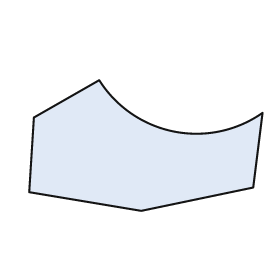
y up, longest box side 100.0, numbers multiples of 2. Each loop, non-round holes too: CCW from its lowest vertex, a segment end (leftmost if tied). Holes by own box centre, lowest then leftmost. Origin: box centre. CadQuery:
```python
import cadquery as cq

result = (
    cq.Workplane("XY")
    .moveTo(-2.0, -28.0)
    .lineTo(46.0, -18.0)
    .lineTo(50.0, 14.0)
    .threePointArc((12.0, 6.0), (-20.0, 28.0))
    .lineTo(-48.0, 12.0)
    .lineTo(-50.0, -20.0)
    .close()
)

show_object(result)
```